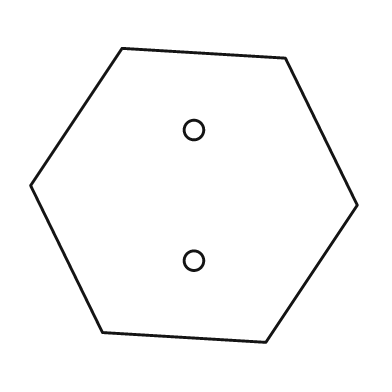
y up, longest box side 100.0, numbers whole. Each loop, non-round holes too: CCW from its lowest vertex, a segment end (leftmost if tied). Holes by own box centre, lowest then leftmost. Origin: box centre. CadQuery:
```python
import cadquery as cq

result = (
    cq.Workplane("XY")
    .moveTo(22.0, -45.0)
    .lineTo(50.0, -3.0)
    .lineTo(28.0, 42.0)
    .lineTo(-22.0, 45.0)
    .lineTo(-50.0, 3.0)
    .lineTo(-28.0, -42.0)
    .close()
    .moveTo(0.0, -20.0)
    .circle(3.0)
    .moveTo(0.0, 20.0)
    .circle(3.0)
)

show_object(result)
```